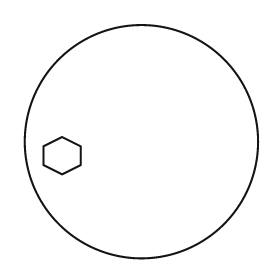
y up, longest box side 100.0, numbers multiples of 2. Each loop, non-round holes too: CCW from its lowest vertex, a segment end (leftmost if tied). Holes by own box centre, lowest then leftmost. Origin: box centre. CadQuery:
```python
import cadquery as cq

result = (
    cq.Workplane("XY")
    .moveTo(0.0, 0.0)
    .circle(50.0)
    .moveTo(-34.0, -14.0)
    .lineTo(-26.0, -10.0)
    .lineTo(-26.0, -2.0)
    .lineTo(-34.0, 2.0)
    .lineTo(-42.0, -2.0)
    .lineTo(-42.0, -10.0)
    .close()
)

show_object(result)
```